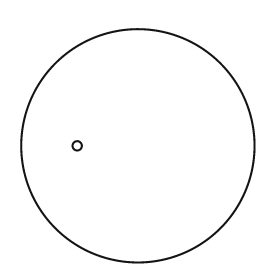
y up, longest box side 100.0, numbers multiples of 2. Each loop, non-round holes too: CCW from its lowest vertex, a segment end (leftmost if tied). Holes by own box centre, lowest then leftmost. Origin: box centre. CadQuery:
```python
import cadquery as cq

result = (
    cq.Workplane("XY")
    .moveTo(0.0, 0.0)
    .circle(50.0)
    .moveTo(-26.0, 0.0)
    .circle(2.0)
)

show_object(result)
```